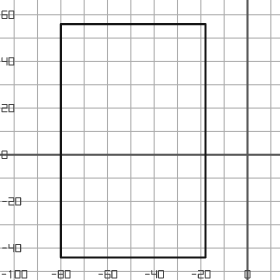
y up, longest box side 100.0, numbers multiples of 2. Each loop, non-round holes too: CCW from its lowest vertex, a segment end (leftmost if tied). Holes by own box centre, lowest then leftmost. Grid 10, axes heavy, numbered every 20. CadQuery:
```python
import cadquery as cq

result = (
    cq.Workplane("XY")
    .moveTo(-80.0, -44.0)
    .lineTo(-18.0, -44.0)
    .lineTo(-18.0, 56.0)
    .lineTo(-80.0, 56.0)
    .close()
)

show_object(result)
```